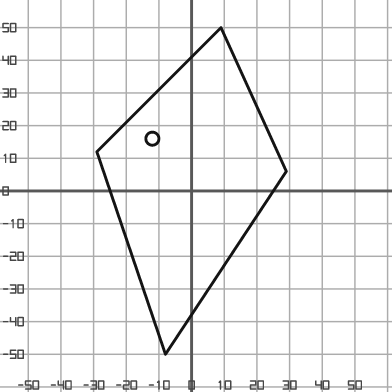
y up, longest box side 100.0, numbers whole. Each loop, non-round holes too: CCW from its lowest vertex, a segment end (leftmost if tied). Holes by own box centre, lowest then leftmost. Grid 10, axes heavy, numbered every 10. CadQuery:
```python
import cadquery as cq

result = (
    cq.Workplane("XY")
    .moveTo(-8.0, -50.0)
    .lineTo(29.0, 6.0)
    .lineTo(9.0, 50.0)
    .lineTo(-29.0, 12.0)
    .close()
    .moveTo(-12.0, 16.0)
    .circle(2.0)
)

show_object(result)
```